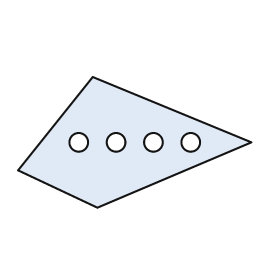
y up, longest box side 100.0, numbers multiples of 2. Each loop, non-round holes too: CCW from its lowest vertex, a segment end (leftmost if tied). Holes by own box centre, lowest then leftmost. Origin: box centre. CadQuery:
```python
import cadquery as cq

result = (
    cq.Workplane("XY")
    .moveTo(-16.0, -28.0)
    .lineTo(50.0, 0.0)
    .lineTo(-18.0, 28.0)
    .lineTo(-50.0, -12.0)
    .close()
    .moveTo(-24.0, 0.0)
    .circle(4.0)
    .moveTo(-8.0, 0.0)
    .circle(4.0)
    .moveTo(8.0, 0.0)
    .circle(4.0)
    .moveTo(24.0, 0.0)
    .circle(4.0)
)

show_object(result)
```